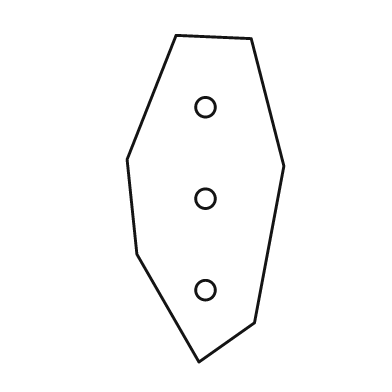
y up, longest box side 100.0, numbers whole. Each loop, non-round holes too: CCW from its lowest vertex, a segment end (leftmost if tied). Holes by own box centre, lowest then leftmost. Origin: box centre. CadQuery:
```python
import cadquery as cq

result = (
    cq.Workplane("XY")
    .moveTo(-2.0, -50.0)
    .lineTo(15.0, -38.0)
    .lineTo(24.0, 10.0)
    .lineTo(14.0, 49.0)
    .lineTo(-9.0, 50.0)
    .lineTo(-24.0, 12.0)
    .lineTo(-21.0, -17.0)
    .close()
    .moveTo(0.0, -28.0)
    .circle(3.0)
    .moveTo(0.0, 0.0)
    .circle(3.0)
    .moveTo(0.0, 28.0)
    .circle(3.0)
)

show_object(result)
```